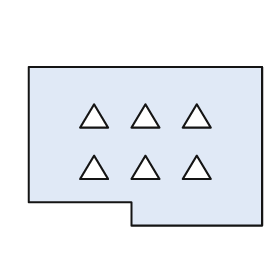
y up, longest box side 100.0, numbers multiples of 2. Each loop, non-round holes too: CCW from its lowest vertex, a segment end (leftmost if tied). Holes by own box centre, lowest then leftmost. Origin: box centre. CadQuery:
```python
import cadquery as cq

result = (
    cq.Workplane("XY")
    .moveTo(-6.0, -34.0)
    .lineTo(50.0, -34.0)
    .lineTo(50.0, 34.0)
    .lineTo(-50.0, 34.0)
    .lineTo(-50.0, -24.0)
    .lineTo(-6.0, -24.0)
    .close()
    .moveTo(-28.0, -14.0)
    .lineTo(-16.0, -14.0)
    .lineTo(-22.0, -4.0)
    .close()
    .moveTo(-6.0, -14.0)
    .lineTo(6.0, -14.0)
    .lineTo(0.0, -4.0)
    .close()
    .moveTo(16.0, -14.0)
    .lineTo(28.0, -14.0)
    .lineTo(22.0, -4.0)
    .close()
    .moveTo(-28.0, 8.0)
    .lineTo(-16.0, 8.0)
    .lineTo(-22.0, 18.0)
    .close()
    .moveTo(-6.0, 8.0)
    .lineTo(6.0, 8.0)
    .lineTo(0.0, 18.0)
    .close()
    .moveTo(16.0, 8.0)
    .lineTo(28.0, 8.0)
    .lineTo(22.0, 18.0)
    .close()
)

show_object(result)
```